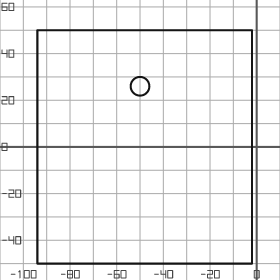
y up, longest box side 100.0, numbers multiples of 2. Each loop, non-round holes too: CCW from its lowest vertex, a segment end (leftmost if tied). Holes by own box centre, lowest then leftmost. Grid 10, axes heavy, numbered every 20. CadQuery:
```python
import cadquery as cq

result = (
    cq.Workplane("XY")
    .moveTo(-94.0, -50.0)
    .lineTo(-2.0, -50.0)
    .lineTo(-2.0, 50.0)
    .lineTo(-94.0, 50.0)
    .close()
    .moveTo(-50.0, 26.0)
    .circle(4.0)
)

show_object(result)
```